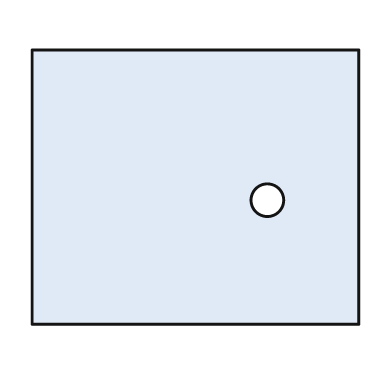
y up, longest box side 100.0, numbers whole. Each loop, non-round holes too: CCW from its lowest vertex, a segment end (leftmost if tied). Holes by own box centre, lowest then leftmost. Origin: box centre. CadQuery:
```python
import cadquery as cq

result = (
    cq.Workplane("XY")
    .moveTo(-50.0, -42.0)
    .lineTo(50.0, -42.0)
    .lineTo(50.0, 42.0)
    .lineTo(-50.0, 42.0)
    .close()
    .moveTo(22.0, -4.0)
    .circle(5.0)
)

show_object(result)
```